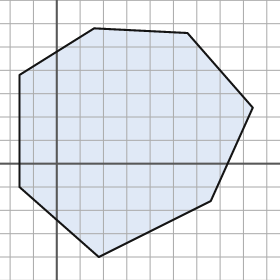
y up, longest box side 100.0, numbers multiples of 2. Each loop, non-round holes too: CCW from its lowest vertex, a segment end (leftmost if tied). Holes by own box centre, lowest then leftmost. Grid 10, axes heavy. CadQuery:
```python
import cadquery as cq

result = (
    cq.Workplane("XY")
    .moveTo(18.0, -40.0)
    .lineTo(66.0, -16.0)
    .lineTo(84.0, 24.0)
    .lineTo(56.0, 56.0)
    .lineTo(16.0, 58.0)
    .lineTo(-16.0, 38.0)
    .lineTo(-16.0, -10.0)
    .close()
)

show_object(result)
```